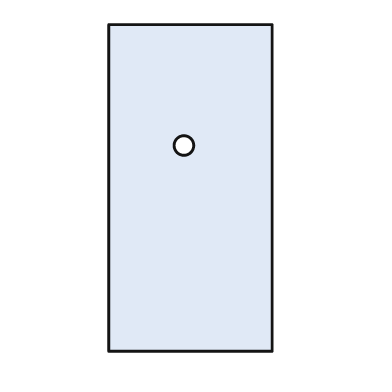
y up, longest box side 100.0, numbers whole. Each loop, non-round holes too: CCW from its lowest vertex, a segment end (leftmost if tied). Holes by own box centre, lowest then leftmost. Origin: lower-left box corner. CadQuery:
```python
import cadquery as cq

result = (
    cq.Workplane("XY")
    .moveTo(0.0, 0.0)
    .lineTo(50.0, 0.0)
    .lineTo(50.0, 100.0)
    .lineTo(0.0, 100.0)
    .close()
    .moveTo(23.0, 63.0)
    .circle(3.0)
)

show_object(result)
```